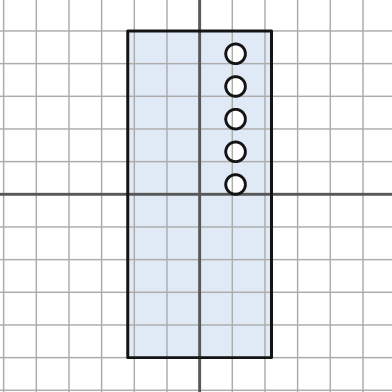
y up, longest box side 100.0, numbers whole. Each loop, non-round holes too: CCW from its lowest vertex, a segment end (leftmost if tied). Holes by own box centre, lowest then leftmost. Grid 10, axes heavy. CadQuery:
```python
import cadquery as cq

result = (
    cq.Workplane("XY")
    .moveTo(-22.0, -50.0)
    .lineTo(22.0, -50.0)
    .lineTo(22.0, 50.0)
    .lineTo(-22.0, 50.0)
    .close()
    .moveTo(11.0, 3.0)
    .circle(3.0)
    .moveTo(11.0, 13.0)
    .circle(3.0)
    .moveTo(11.0, 23.0)
    .circle(3.0)
    .moveTo(11.0, 33.0)
    .circle(3.0)
    .moveTo(11.0, 43.0)
    .circle(3.0)
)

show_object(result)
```